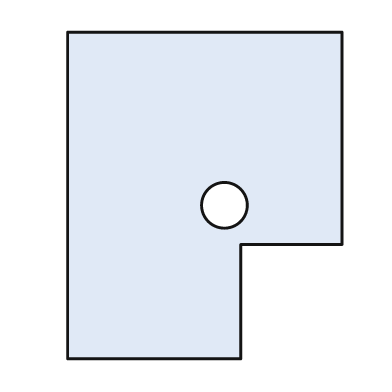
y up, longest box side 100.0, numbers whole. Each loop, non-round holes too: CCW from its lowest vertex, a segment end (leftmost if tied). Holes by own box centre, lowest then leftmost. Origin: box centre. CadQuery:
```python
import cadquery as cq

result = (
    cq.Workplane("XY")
    .moveTo(-42.0, -50.0)
    .lineTo(11.0, -50.0)
    .lineTo(11.0, -15.0)
    .lineTo(42.0, -15.0)
    .lineTo(42.0, 50.0)
    .lineTo(-42.0, 50.0)
    .close()
    .moveTo(6.0, -3.0)
    .circle(7.0)
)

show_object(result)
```